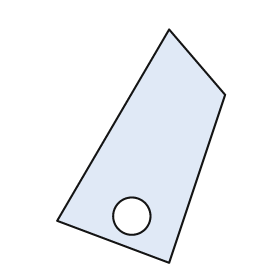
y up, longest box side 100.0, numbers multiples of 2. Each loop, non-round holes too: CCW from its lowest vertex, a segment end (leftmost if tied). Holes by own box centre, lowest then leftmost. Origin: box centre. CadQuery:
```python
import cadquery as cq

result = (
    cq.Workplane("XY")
    .moveTo(12.0, -50.0)
    .lineTo(36.0, 22.0)
    .lineTo(12.0, 50.0)
    .lineTo(-36.0, -32.0)
    .close()
    .moveTo(-4.0, -30.0)
    .circle(8.0)
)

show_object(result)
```